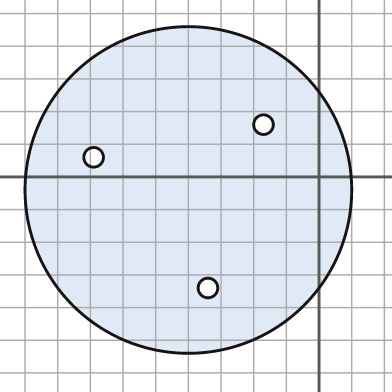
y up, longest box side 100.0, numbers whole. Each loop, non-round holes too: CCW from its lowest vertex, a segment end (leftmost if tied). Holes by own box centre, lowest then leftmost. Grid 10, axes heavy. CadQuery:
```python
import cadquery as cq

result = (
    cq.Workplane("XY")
    .moveTo(-40.0, -4.0)
    .circle(50.0)
    .moveTo(-34.0, -34.0)
    .circle(3.0)
    .moveTo(-69.0, 6.0)
    .circle(3.0)
    .moveTo(-17.0, 16.0)
    .circle(3.0)
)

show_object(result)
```